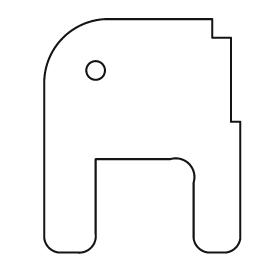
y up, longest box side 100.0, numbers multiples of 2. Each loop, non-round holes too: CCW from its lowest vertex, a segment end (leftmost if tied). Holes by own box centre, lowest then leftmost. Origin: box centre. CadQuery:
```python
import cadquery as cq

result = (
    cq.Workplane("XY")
    .moveTo(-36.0, -50.0)
    .lineTo(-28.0, -50.0)
    .threePointArc((-22.0, -48.0), (-20.0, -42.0))
    .lineTo(-20.0, -10.0)
    .lineTo(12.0, -10.0)
    .threePointArc((20.0, -12.0), (22.0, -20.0))
    .lineTo(22.0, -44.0)
    .threePointArc((24.0, -48.0), (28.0, -50.0))
    .lineTo(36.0, -50.0)
    .threePointArc((40.0, -48.0), (42.0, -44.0))
    .lineTo(42.0, 6.0)
    .lineTo(38.0, 6.0)
    .lineTo(38.0, 42.0)
    .lineTo(30.0, 42.0)
    .lineTo(30.0, 50.0)
    .lineTo(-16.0, 50.0)
    .threePointArc((-34.0, 42.0), (-42.0, 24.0))
    .lineTo(-42.0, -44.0)
    .threePointArc((-40.0, -48.0), (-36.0, -50.0))
    .close()
    .moveTo(-20.0, 28.0)
    .circle(4.0)
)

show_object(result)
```